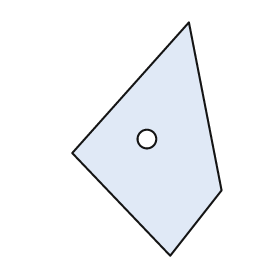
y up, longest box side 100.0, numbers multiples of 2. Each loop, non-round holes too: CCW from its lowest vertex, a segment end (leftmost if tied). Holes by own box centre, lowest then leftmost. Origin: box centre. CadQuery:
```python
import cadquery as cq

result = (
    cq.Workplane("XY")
    .moveTo(10.0, -50.0)
    .lineTo(32.0, -22.0)
    .lineTo(18.0, 50.0)
    .lineTo(-32.0, -6.0)
    .close()
    .moveTo(0.0, 0.0)
    .circle(4.0)
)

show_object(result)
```